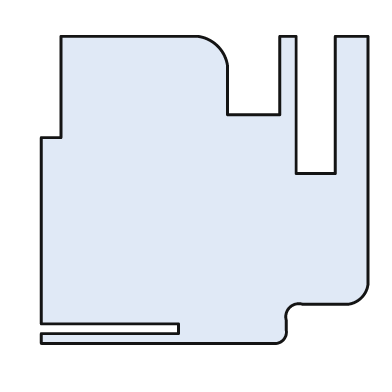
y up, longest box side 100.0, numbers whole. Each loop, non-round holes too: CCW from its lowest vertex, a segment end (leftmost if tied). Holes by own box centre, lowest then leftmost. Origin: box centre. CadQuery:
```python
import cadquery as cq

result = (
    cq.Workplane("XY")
    .moveTo(-50.0, -47.0)
    .lineTo(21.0, -47.0)
    .threePointArc((24.0, -46.0), (25.0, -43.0))
    .lineTo(25.0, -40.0)
    .threePointArc((26.0, -36.0), (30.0, -35.0))
    .lineTo(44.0, -35.0)
    .threePointArc((48.0, -33.0), (50.0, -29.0))
    .lineTo(50.0, 47.0)
    .lineTo(40.0, 47.0)
    .lineTo(40.0, 5.0)
    .lineTo(28.0, 5.0)
    .lineTo(28.0, 47.0)
    .lineTo(23.0, 47.0)
    .lineTo(23.0, 23.0)
    .lineTo(7.0, 23.0)
    .lineTo(7.0, 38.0)
    .threePointArc((4.0, 44.0), (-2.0, 47.0))
    .lineTo(-44.0, 47.0)
    .lineTo(-44.0, 16.0)
    .lineTo(-50.0, 16.0)
    .lineTo(-50.0, -41.0)
    .lineTo(-8.0, -41.0)
    .lineTo(-8.0, -44.0)
    .lineTo(-50.0, -44.0)
    .close()
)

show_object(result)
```